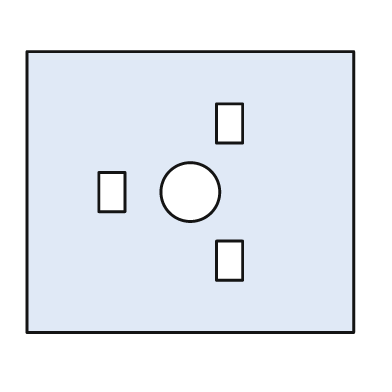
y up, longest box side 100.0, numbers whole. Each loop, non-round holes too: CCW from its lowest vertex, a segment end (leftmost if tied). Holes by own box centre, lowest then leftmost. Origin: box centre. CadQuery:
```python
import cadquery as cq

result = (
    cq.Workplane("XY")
    .moveTo(-50.0, -43.0)
    .lineTo(50.0, -43.0)
    .lineTo(50.0, 43.0)
    .lineTo(-50.0, 43.0)
    .close()
    .moveTo(8.0, -27.0)
    .lineTo(16.0, -27.0)
    .lineTo(16.0, -15.0)
    .lineTo(8.0, -15.0)
    .close()
    .moveTo(-28.0, -6.0)
    .lineTo(-20.0, -6.0)
    .lineTo(-20.0, 6.0)
    .lineTo(-28.0, 6.0)
    .close()
    .moveTo(0.0, 0.0)
    .circle(9.0)
    .moveTo(8.0, 15.0)
    .lineTo(16.0, 15.0)
    .lineTo(16.0, 27.0)
    .lineTo(8.0, 27.0)
    .close()
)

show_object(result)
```